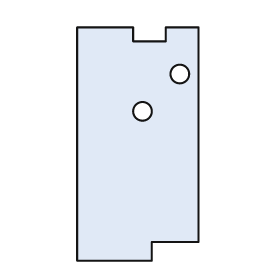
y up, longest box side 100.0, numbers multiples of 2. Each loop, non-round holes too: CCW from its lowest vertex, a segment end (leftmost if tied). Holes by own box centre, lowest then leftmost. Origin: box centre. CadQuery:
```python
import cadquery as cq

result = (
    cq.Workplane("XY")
    .moveTo(-26.0, -50.0)
    .lineTo(6.0, -50.0)
    .lineTo(6.0, -42.0)
    .lineTo(26.0, -42.0)
    .lineTo(26.0, 50.0)
    .lineTo(12.0, 50.0)
    .lineTo(12.0, 44.0)
    .lineTo(-2.0, 44.0)
    .lineTo(-2.0, 50.0)
    .lineTo(-26.0, 50.0)
    .close()
    .moveTo(2.0, 14.0)
    .circle(4.0)
    .moveTo(18.0, 30.0)
    .circle(4.0)
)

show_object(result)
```